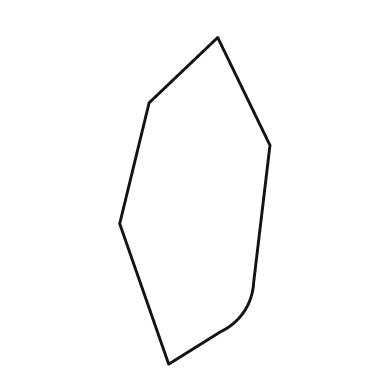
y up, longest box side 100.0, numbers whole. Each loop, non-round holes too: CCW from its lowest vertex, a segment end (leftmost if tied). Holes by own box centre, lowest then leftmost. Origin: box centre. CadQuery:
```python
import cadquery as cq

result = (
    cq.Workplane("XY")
    .moveTo(-8.0, -50.0)
    .lineTo(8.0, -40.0)
    .threePointArc((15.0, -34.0), (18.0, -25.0))
    .lineTo(23.0, 17.0)
    .lineTo(7.0, 50.0)
    .lineTo(-14.0, 30.0)
    .lineTo(-23.0, -7.0)
    .close()
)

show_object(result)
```